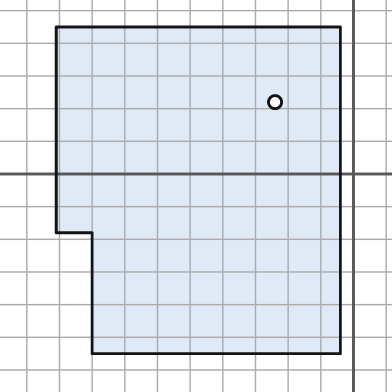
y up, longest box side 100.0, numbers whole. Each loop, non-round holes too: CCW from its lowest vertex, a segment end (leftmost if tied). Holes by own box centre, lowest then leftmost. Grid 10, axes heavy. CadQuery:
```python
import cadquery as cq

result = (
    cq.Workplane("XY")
    .moveTo(-80.0, -55.0)
    .lineTo(-4.0, -55.0)
    .lineTo(-4.0, 45.0)
    .lineTo(-91.0, 45.0)
    .lineTo(-91.0, -18.0)
    .lineTo(-80.0, -18.0)
    .close()
    .moveTo(-24.0, 22.0)
    .circle(2.0)
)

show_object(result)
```